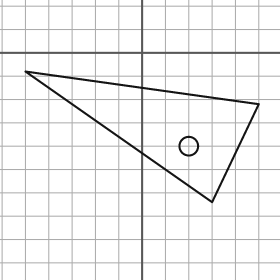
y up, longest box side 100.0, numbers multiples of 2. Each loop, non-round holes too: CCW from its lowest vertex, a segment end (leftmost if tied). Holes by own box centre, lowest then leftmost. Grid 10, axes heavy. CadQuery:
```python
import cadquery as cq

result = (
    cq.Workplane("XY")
    .moveTo(30.0, -64.0)
    .lineTo(50.0, -22.0)
    .lineTo(-50.0, -8.0)
    .close()
    .moveTo(20.0, -40.0)
    .circle(4.0)
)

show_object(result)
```